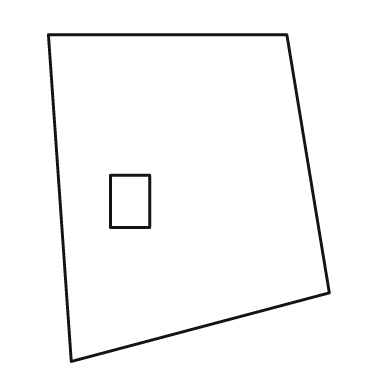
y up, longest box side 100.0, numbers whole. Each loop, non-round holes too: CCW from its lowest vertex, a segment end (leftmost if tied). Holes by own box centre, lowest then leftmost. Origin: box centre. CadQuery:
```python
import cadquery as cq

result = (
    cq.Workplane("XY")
    .moveTo(-36.0, -50.0)
    .lineTo(43.0, -29.0)
    .lineTo(30.0, 50.0)
    .lineTo(-43.0, 50.0)
    .close()
    .moveTo(-24.0, -9.0)
    .lineTo(-12.0, -9.0)
    .lineTo(-12.0, 7.0)
    .lineTo(-24.0, 7.0)
    .close()
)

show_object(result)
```